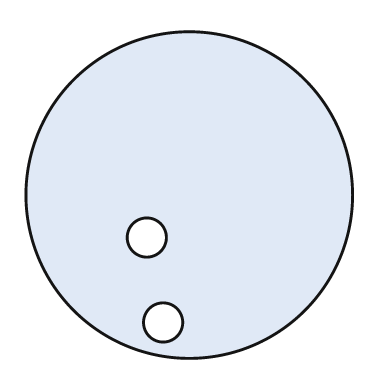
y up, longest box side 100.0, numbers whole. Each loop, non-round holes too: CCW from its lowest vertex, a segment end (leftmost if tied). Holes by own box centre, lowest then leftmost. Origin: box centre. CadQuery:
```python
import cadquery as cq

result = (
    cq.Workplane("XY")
    .moveTo(0.0, 0.0)
    .circle(50.0)
    .moveTo(-8.0, -39.0)
    .circle(6.0)
    .moveTo(-13.0, -13.0)
    .circle(6.0)
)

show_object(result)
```